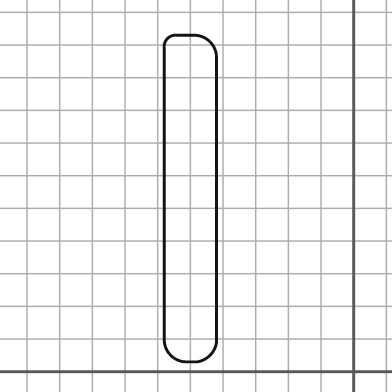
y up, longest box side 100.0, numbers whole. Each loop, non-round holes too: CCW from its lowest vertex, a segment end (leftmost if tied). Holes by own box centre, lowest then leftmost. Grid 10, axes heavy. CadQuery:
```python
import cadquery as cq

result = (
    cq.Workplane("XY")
    .moveTo(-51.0, 3.0)
    .lineTo(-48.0, 3.0)
    .threePointArc((-44.0, 5.0), (-42.0, 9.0))
    .lineTo(-42.0, 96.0)
    .threePointArc((-44.0, 101.0), (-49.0, 103.0))
    .lineTo(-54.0, 103.0)
    .threePointArc((-57.0, 102.0), (-58.0, 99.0))
    .lineTo(-58.0, 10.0)
    .threePointArc((-56.0, 5.0), (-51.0, 3.0))
    .close()
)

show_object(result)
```